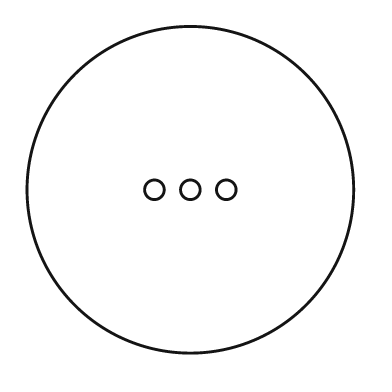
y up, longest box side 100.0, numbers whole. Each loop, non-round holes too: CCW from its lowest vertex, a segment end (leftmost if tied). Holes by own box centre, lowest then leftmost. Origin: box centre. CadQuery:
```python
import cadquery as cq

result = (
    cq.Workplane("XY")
    .moveTo(0.0, 0.0)
    .circle(50.0)
    .moveTo(-11.0, 0.0)
    .circle(3.0)
    .moveTo(0.0, 0.0)
    .circle(3.0)
    .moveTo(11.0, 0.0)
    .circle(3.0)
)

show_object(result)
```